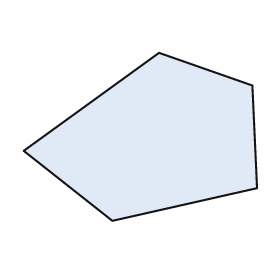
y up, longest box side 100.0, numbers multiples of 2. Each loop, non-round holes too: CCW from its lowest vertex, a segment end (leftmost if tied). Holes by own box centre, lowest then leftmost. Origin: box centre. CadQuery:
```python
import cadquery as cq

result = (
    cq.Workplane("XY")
    .moveTo(-12.0, -36.0)
    .lineTo(50.0, -22.0)
    .lineTo(48.0, 22.0)
    .lineTo(8.0, 36.0)
    .lineTo(-50.0, -6.0)
    .close()
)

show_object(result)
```